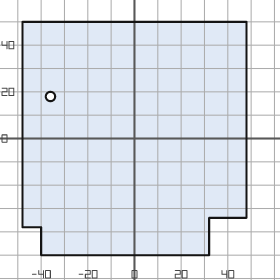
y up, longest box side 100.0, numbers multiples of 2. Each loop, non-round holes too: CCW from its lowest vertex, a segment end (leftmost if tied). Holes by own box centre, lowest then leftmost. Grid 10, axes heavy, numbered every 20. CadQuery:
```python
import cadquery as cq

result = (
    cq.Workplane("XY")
    .moveTo(-40.0, -50.0)
    .lineTo(32.0, -50.0)
    .lineTo(32.0, -34.0)
    .lineTo(48.0, -34.0)
    .lineTo(48.0, 50.0)
    .lineTo(-48.0, 50.0)
    .lineTo(-48.0, -38.0)
    .lineTo(-40.0, -38.0)
    .close()
    .moveTo(-36.0, 18.0)
    .circle(2.0)
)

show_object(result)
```